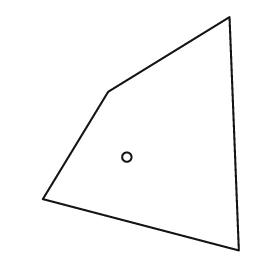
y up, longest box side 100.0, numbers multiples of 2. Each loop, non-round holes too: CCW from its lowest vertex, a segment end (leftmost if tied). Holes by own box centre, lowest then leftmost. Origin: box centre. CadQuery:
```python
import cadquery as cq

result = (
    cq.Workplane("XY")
    .moveTo(42.0, -50.0)
    .lineTo(38.0, 50.0)
    .lineTo(-14.0, 18.0)
    .lineTo(-42.0, -28.0)
    .close()
    .moveTo(-6.0, -10.0)
    .circle(2.0)
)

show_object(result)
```